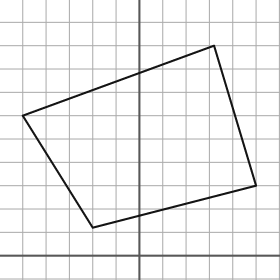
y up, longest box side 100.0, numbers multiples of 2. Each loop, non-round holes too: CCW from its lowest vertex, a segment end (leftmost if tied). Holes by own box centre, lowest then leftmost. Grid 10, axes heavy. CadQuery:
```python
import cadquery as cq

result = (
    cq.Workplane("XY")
    .moveTo(-20.0, 12.0)
    .lineTo(50.0, 30.0)
    .lineTo(32.0, 90.0)
    .lineTo(-50.0, 60.0)
    .close()
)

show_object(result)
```